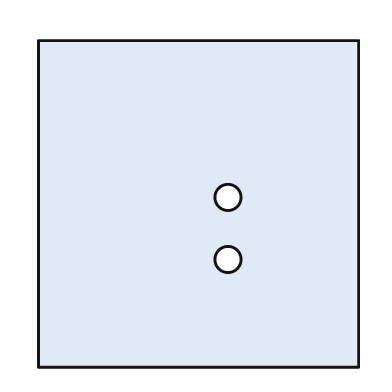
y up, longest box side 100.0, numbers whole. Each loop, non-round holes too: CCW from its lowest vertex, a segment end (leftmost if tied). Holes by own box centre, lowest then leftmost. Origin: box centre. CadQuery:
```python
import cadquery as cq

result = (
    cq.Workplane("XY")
    .moveTo(-49.0, -50.0)
    .lineTo(49.0, -50.0)
    .lineTo(49.0, 50.0)
    .lineTo(-49.0, 50.0)
    .close()
    .moveTo(9.0, -17.0)
    .circle(4.0)
    .moveTo(9.0, 2.0)
    .circle(4.0)
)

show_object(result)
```